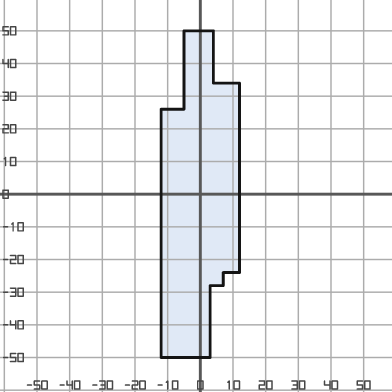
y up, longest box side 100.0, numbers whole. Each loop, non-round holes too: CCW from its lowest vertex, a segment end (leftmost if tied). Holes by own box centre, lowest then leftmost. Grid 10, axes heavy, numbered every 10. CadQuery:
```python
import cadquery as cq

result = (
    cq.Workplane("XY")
    .moveTo(-12.0, -50.0)
    .lineTo(3.0, -50.0)
    .lineTo(3.0, -28.0)
    .lineTo(7.0, -28.0)
    .lineTo(7.0, -24.0)
    .lineTo(12.0, -24.0)
    .lineTo(12.0, 34.0)
    .lineTo(4.0, 34.0)
    .lineTo(4.0, 50.0)
    .lineTo(-5.0, 50.0)
    .lineTo(-5.0, 26.0)
    .lineTo(-12.0, 26.0)
    .close()
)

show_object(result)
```